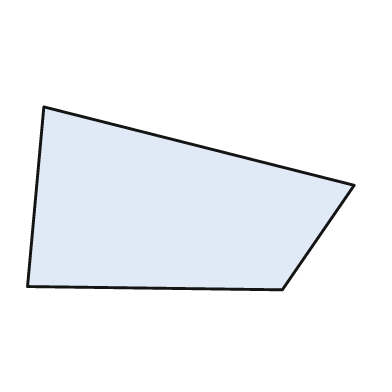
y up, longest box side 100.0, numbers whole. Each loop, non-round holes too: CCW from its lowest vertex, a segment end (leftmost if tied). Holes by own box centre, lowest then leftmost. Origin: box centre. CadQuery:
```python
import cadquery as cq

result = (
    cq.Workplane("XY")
    .moveTo(28.0, -28.0)
    .lineTo(50.0, 4.0)
    .lineTo(-45.0, 28.0)
    .lineTo(-50.0, -27.0)
    .close()
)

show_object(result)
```